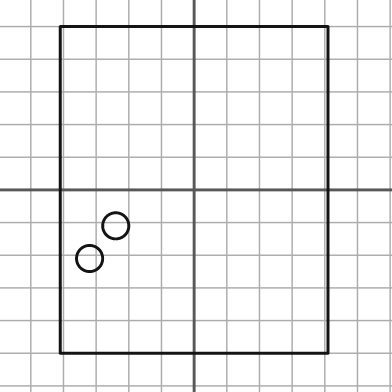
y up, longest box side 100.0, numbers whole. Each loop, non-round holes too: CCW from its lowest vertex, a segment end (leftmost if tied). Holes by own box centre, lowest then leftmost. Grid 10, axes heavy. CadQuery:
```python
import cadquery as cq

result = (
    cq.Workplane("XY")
    .moveTo(-41.0, -50.0)
    .lineTo(41.0, -50.0)
    .lineTo(41.0, 50.0)
    .lineTo(-41.0, 50.0)
    .close()
    .moveTo(-32.0, -21.0)
    .circle(4.0)
    .moveTo(-24.0, -11.0)
    .circle(4.0)
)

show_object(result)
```